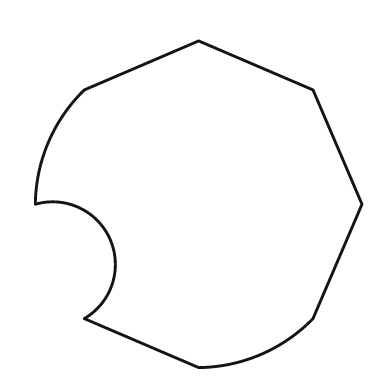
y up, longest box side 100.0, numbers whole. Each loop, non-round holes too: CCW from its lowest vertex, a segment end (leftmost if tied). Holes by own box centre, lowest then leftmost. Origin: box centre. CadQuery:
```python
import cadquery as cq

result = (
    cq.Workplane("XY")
    .moveTo(0.0, -50.0)
    .threePointArc((19.0, -46.0), (35.0, -35.0))
    .lineTo(50.0, 0.0)
    .lineTo(35.0, 35.0)
    .lineTo(0.0, 50.0)
    .lineTo(-35.0, 35.0)
    .threePointArc((-46.0, 19.0), (-50.0, 0.0))
    .threePointArc((-27.0, -11.0), (-35.0, -35.0))
    .close()
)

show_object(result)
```